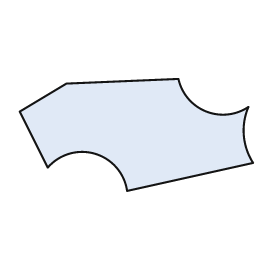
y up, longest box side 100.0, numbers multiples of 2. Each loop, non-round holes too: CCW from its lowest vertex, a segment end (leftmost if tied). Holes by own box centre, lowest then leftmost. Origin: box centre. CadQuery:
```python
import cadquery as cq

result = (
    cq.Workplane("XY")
    .moveTo(-4.0, -24.0)
    .lineTo(50.0, -12.0)
    .threePointArc((46.0, 0.0), (48.0, 12.0))
    .threePointArc((30.0, 10.0), (18.0, 24.0))
    .lineTo(-30.0, 22.0)
    .lineTo(-50.0, 10.0)
    .lineTo(-38.0, -14.0)
    .threePointArc((-18.0, -8.0), (-4.0, -24.0))
    .close()
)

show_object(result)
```